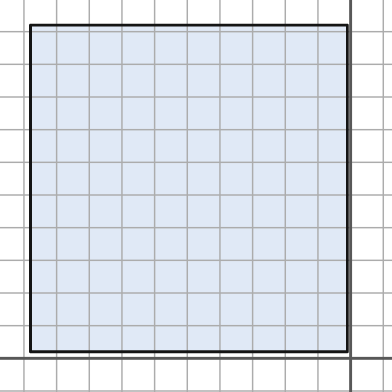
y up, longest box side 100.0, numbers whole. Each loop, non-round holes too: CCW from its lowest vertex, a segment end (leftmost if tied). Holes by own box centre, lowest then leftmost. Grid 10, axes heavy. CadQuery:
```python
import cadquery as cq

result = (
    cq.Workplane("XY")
    .moveTo(-98.0, 2.0)
    .lineTo(-1.0, 2.0)
    .lineTo(-1.0, 102.0)
    .lineTo(-98.0, 102.0)
    .close()
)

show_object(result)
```